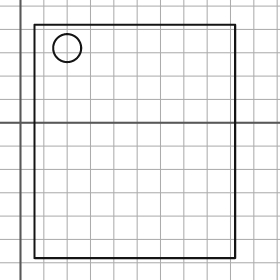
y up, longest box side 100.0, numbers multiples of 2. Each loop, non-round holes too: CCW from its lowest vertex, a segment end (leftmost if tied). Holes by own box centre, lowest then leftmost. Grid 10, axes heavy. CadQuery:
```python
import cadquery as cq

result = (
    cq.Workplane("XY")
    .moveTo(6.0, -58.0)
    .lineTo(92.0, -58.0)
    .lineTo(92.0, 42.0)
    .lineTo(6.0, 42.0)
    .close()
    .moveTo(20.0, 32.0)
    .circle(6.0)
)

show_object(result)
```